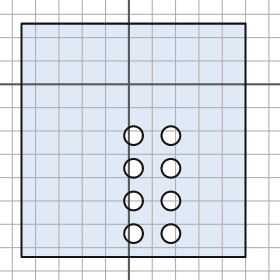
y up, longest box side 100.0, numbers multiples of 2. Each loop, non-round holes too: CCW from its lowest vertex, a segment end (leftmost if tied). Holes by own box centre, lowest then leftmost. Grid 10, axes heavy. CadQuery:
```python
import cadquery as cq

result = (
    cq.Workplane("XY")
    .moveTo(-46.0, -74.0)
    .lineTo(50.0, -74.0)
    .lineTo(50.0, 26.0)
    .lineTo(-46.0, 26.0)
    .close()
    .moveTo(2.0, -64.0)
    .circle(4.0)
    .moveTo(18.0, -64.0)
    .circle(4.0)
    .moveTo(2.0, -50.0)
    .circle(4.0)
    .moveTo(18.0, -50.0)
    .circle(4.0)
    .moveTo(2.0, -36.0)
    .circle(4.0)
    .moveTo(18.0, -36.0)
    .circle(4.0)
    .moveTo(2.0, -22.0)
    .circle(4.0)
    .moveTo(18.0, -22.0)
    .circle(4.0)
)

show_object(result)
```